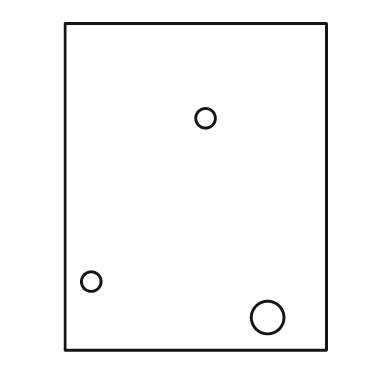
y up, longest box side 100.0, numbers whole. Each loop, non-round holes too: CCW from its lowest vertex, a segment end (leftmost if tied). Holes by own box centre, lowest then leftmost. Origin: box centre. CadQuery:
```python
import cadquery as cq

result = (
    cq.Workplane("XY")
    .moveTo(-40.0, -50.0)
    .lineTo(40.0, -50.0)
    .lineTo(40.0, 50.0)
    .lineTo(-40.0, 50.0)
    .close()
    .moveTo(22.0, -40.0)
    .circle(5.0)
    .moveTo(-32.0, -29.0)
    .circle(3.0)
    .moveTo(3.0, 21.0)
    .circle(3.0)
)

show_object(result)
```